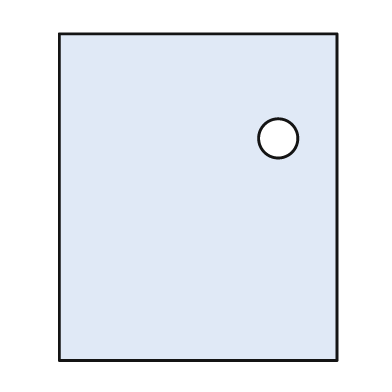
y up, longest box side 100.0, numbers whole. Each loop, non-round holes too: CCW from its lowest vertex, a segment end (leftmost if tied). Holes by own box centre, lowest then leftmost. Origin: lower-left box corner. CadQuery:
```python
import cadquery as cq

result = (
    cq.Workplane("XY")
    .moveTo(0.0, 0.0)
    .lineTo(85.0, 0.0)
    .lineTo(85.0, 100.0)
    .lineTo(0.0, 100.0)
    .close()
    .moveTo(67.0, 68.0)
    .circle(6.0)
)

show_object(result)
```